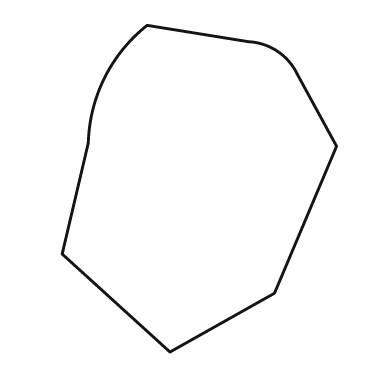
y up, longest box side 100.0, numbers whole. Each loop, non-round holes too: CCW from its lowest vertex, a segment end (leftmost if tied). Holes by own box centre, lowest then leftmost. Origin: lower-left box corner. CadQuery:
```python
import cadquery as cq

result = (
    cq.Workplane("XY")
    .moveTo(33.0, 0.0)
    .lineTo(65.0, 18.0)
    .lineTo(84.0, 63.0)
    .lineTo(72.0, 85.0)
    .threePointArc((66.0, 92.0), (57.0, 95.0))
    .lineTo(26.0, 100.0)
    .threePointArc((13.0, 84.0), (8.0, 64.0))
    .lineTo(0.0, 30.0)
    .close()
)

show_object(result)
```